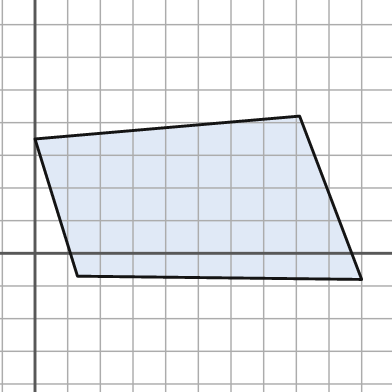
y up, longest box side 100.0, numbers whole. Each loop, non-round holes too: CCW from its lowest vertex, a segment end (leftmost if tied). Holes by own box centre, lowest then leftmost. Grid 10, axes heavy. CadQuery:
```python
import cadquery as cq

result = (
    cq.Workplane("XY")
    .moveTo(100.0, -8.0)
    .lineTo(81.0, 42.0)
    .lineTo(0.0, 35.0)
    .lineTo(13.0, -7.0)
    .close()
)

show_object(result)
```